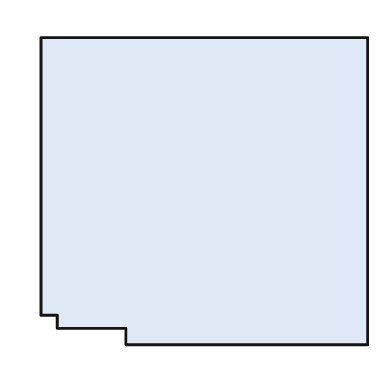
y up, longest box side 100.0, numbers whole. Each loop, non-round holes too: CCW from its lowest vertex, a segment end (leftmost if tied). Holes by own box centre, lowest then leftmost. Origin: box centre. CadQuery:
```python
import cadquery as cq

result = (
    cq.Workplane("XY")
    .moveTo(-24.0, -47.0)
    .lineTo(50.0, -47.0)
    .lineTo(50.0, 47.0)
    .lineTo(-50.0, 47.0)
    .lineTo(-50.0, -38.0)
    .lineTo(-45.0, -38.0)
    .lineTo(-45.0, -42.0)
    .lineTo(-24.0, -42.0)
    .close()
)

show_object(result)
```